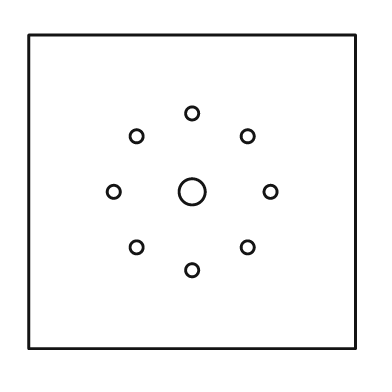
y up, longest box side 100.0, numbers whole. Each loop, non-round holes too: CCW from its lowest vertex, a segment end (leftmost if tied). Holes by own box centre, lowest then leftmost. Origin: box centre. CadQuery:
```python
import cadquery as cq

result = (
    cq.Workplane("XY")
    .moveTo(-50.0, -48.0)
    .lineTo(50.0, -48.0)
    .lineTo(50.0, 48.0)
    .lineTo(-50.0, 48.0)
    .close()
    .moveTo(0.0, -24.0)
    .circle(2.0)
    .moveTo(-17.0, -17.0)
    .circle(2.0)
    .moveTo(17.0, -17.0)
    .circle(2.0)
    .moveTo(-24.0, 0.0)
    .circle(2.0)
    .moveTo(0.0, 0.0)
    .circle(4.0)
    .moveTo(24.0, 0.0)
    .circle(2.0)
    .moveTo(-17.0, 17.0)
    .circle(2.0)
    .moveTo(17.0, 17.0)
    .circle(2.0)
    .moveTo(0.0, 24.0)
    .circle(2.0)
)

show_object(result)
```